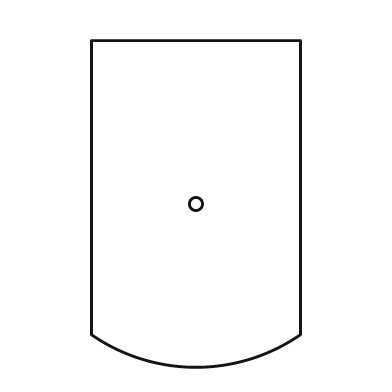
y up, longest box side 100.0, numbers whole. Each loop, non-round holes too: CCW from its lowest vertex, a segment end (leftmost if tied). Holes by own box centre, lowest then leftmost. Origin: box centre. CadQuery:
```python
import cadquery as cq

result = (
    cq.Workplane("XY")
    .moveTo(-32.0, -40.0)
    .threePointArc((0.0, -50.0), (32.0, -40.0))
    .lineTo(32.0, 50.0)
    .lineTo(-32.0, 50.0)
    .close()
    .moveTo(0.0, 0.0)
    .circle(2.0)
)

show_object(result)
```